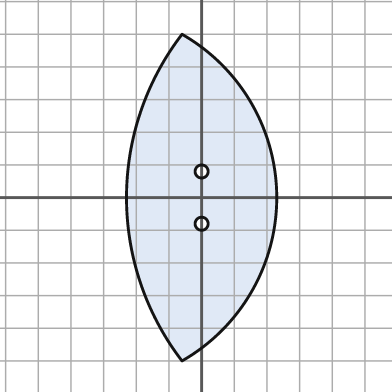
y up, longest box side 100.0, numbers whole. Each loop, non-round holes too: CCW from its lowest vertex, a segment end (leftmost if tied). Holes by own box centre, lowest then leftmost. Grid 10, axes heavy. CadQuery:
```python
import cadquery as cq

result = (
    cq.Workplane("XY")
    .moveTo(-6.0, -50.0)
    .threePointArc((23.0, 0.0), (-6.0, 50.0))
    .threePointArc((-23.0, 0.0), (-6.0, -50.0))
    .close()
    .moveTo(0.0, -8.0)
    .circle(2.0)
    .moveTo(0.0, 8.0)
    .circle(2.0)
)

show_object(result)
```